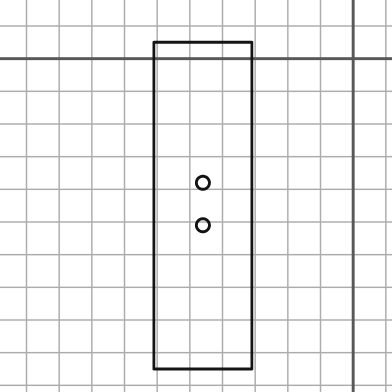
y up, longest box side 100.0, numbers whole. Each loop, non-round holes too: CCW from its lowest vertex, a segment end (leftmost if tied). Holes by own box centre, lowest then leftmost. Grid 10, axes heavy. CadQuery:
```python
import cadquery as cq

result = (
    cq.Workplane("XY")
    .moveTo(-61.0, -95.0)
    .lineTo(-31.0, -95.0)
    .lineTo(-31.0, 5.0)
    .lineTo(-61.0, 5.0)
    .close()
    .moveTo(-46.0, -51.0)
    .circle(2.0)
    .moveTo(-46.0, -38.0)
    .circle(2.0)
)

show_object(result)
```